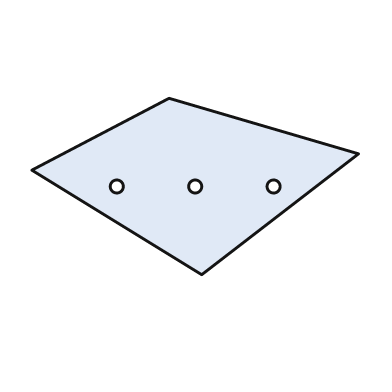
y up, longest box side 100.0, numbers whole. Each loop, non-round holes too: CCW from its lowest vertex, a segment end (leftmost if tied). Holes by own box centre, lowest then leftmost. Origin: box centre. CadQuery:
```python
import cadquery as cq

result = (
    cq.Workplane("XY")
    .moveTo(2.0, -27.0)
    .lineTo(50.0, 10.0)
    .lineTo(-8.0, 27.0)
    .lineTo(-50.0, 5.0)
    .close()
    .moveTo(-24.0, 0.0)
    .circle(2.0)
    .moveTo(0.0, 0.0)
    .circle(2.0)
    .moveTo(24.0, 0.0)
    .circle(2.0)
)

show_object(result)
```